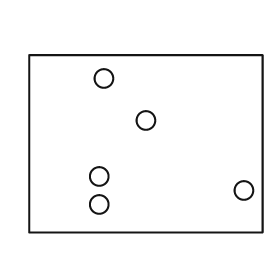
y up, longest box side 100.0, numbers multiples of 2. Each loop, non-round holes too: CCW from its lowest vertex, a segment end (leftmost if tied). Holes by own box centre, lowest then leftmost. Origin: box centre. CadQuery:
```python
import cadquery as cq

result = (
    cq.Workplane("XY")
    .moveTo(-50.0, -38.0)
    .lineTo(50.0, -38.0)
    .lineTo(50.0, 38.0)
    .lineTo(-50.0, 38.0)
    .close()
    .moveTo(-20.0, -26.0)
    .circle(4.0)
    .moveTo(42.0, -20.0)
    .circle(4.0)
    .moveTo(-20.0, -14.0)
    .circle(4.0)
    .moveTo(0.0, 10.0)
    .circle(4.0)
    .moveTo(-18.0, 28.0)
    .circle(4.0)
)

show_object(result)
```